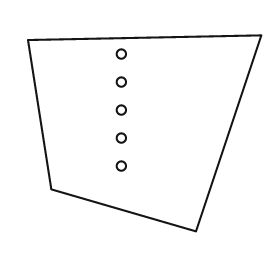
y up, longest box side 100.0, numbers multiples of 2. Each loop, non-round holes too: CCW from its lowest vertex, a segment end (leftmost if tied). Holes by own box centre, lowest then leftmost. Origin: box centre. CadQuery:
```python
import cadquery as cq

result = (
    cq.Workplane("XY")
    .moveTo(22.0, -42.0)
    .lineTo(50.0, 42.0)
    .lineTo(-50.0, 40.0)
    .lineTo(-40.0, -24.0)
    .close()
    .moveTo(-10.0, -14.0)
    .circle(2.0)
    .moveTo(-10.0, -2.0)
    .circle(2.0)
    .moveTo(-10.0, 10.0)
    .circle(2.0)
    .moveTo(-10.0, 22.0)
    .circle(2.0)
    .moveTo(-10.0, 34.0)
    .circle(2.0)
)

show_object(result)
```